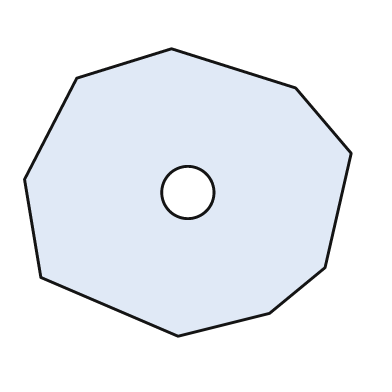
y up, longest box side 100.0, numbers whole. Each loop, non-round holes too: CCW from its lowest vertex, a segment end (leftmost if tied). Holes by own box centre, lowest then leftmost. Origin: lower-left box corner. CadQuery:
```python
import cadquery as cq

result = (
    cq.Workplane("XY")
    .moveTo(47.0, 0.0)
    .lineTo(75.0, 7.0)
    .lineTo(92.0, 21.0)
    .lineTo(100.0, 56.0)
    .lineTo(83.0, 76.0)
    .lineTo(45.0, 88.0)
    .lineTo(16.0, 79.0)
    .lineTo(0.0, 48.0)
    .lineTo(5.0, 18.0)
    .close()
    .moveTo(50.0, 44.0)
    .circle(8.0)
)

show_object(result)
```